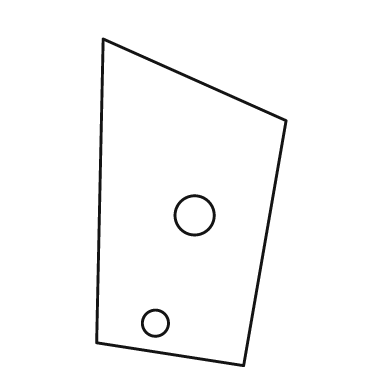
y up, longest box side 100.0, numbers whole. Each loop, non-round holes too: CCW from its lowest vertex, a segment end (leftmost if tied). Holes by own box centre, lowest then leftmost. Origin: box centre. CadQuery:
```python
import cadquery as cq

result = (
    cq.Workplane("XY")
    .moveTo(16.0, -50.0)
    .lineTo(29.0, 25.0)
    .lineTo(-27.0, 50.0)
    .lineTo(-29.0, -43.0)
    .close()
    .moveTo(-11.0, -37.0)
    .circle(4.0)
    .moveTo(1.0, -4.0)
    .circle(6.0)
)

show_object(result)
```